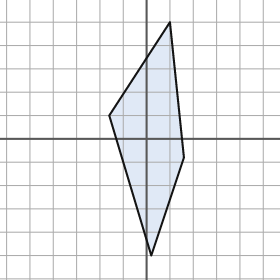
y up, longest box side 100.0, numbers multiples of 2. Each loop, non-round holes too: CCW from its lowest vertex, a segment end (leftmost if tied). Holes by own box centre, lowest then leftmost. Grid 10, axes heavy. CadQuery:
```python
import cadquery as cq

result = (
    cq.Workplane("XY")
    .moveTo(2.0, -50.0)
    .lineTo(16.0, -8.0)
    .lineTo(10.0, 50.0)
    .lineTo(-16.0, 10.0)
    .close()
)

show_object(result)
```